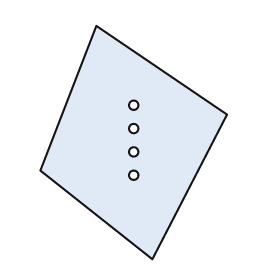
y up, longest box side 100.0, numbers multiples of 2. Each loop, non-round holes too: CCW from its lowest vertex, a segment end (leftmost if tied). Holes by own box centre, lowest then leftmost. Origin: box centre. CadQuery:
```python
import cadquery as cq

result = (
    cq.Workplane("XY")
    .moveTo(8.0, -50.0)
    .lineTo(40.0, 12.0)
    .lineTo(-16.0, 50.0)
    .lineTo(-40.0, -12.0)
    .close()
    .moveTo(0.0, -14.0)
    .circle(2.0)
    .moveTo(0.0, -4.0)
    .circle(2.0)
    .moveTo(0.0, 6.0)
    .circle(2.0)
    .moveTo(0.0, 16.0)
    .circle(2.0)
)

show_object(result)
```